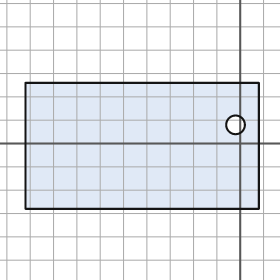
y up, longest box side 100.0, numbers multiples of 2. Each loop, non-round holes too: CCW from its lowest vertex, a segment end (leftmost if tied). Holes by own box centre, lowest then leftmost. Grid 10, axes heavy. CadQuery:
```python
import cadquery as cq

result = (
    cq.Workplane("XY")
    .moveTo(-92.0, -28.0)
    .lineTo(8.0, -28.0)
    .lineTo(8.0, 26.0)
    .lineTo(-92.0, 26.0)
    .close()
    .moveTo(-2.0, 8.0)
    .circle(4.0)
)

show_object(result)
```